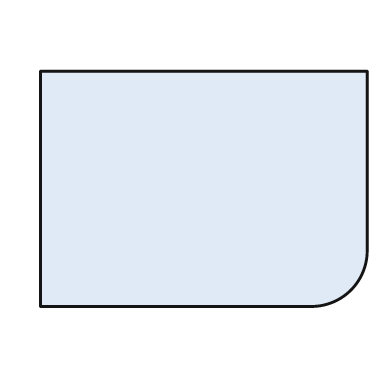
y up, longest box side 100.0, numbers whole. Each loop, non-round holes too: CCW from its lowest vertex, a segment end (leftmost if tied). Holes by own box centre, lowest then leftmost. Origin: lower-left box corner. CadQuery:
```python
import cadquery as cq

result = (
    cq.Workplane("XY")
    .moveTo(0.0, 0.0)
    .lineTo(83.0, 0.0)
    .threePointArc((95.0, 5.0), (100.0, 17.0))
    .lineTo(100.0, 72.0)
    .lineTo(0.0, 72.0)
    .close()
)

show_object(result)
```